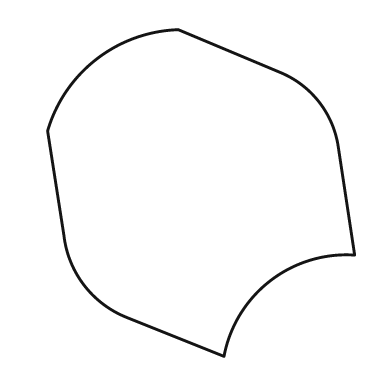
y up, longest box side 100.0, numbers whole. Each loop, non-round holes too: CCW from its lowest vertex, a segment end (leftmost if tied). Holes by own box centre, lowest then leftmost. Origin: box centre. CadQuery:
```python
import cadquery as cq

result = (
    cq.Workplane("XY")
    .moveTo(7.0, -50.0)
    .threePointArc((21.0, -27.0), (47.0, -19.0))
    .lineTo(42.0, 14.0)
    .threePointArc((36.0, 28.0), (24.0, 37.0))
    .lineTo(-7.0, 50.0)
    .threePointArc((-32.0, 41.0), (-47.0, 19.0))
    .lineTo(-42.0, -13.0)
    .threePointArc((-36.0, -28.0), (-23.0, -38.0))
    .close()
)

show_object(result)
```